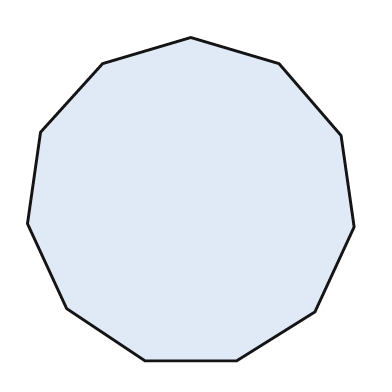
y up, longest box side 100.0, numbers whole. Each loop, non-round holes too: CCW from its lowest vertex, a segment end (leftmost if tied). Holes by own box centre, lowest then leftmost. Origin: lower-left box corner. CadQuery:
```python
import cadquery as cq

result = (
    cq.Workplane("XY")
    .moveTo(36.0, 0.0)
    .lineTo(64.0, 0.0)
    .lineTo(88.0, 15.0)
    .lineTo(100.0, 41.0)
    .lineTo(96.0, 69.0)
    .lineTo(77.0, 91.0)
    .lineTo(50.0, 99.0)
    .lineTo(23.0, 91.0)
    .lineTo(4.0, 70.0)
    .lineTo(0.0, 42.0)
    .lineTo(12.0, 16.0)
    .close()
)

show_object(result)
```